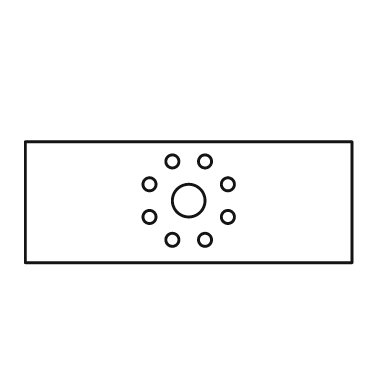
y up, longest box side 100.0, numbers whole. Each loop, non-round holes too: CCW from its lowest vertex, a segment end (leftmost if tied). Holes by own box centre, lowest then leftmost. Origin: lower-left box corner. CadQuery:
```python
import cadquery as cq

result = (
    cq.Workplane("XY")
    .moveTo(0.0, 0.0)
    .lineTo(100.0, 0.0)
    .lineTo(100.0, 37.0)
    .lineTo(0.0, 37.0)
    .close()
    .moveTo(45.0, 7.0)
    .circle(2.0)
    .moveTo(55.0, 7.0)
    .circle(2.0)
    .moveTo(38.0, 14.0)
    .circle(2.0)
    .moveTo(62.0, 14.0)
    .circle(2.0)
    .moveTo(50.0, 19.0)
    .circle(5.0)
    .moveTo(38.0, 24.0)
    .circle(2.0)
    .moveTo(62.0, 24.0)
    .circle(2.0)
    .moveTo(45.0, 31.0)
    .circle(2.0)
    .moveTo(55.0, 31.0)
    .circle(2.0)
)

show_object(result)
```